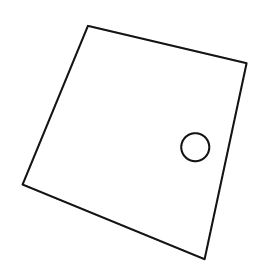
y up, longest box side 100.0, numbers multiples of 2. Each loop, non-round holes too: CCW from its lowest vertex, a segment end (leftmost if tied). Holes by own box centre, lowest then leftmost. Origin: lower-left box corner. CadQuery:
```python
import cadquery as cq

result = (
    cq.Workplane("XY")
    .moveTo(78.0, 0.0)
    .lineTo(96.0, 84.0)
    .lineTo(28.0, 100.0)
    .lineTo(0.0, 32.0)
    .close()
    .moveTo(74.0, 48.0)
    .circle(6.0)
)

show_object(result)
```